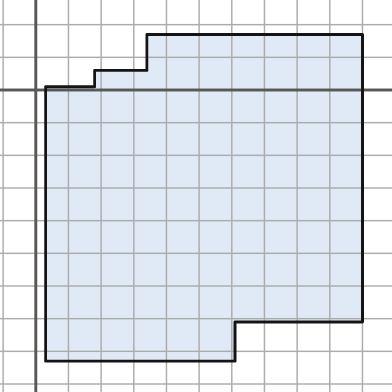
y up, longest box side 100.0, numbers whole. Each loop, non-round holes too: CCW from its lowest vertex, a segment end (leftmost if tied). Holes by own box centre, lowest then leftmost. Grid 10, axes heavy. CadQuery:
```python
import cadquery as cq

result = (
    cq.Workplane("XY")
    .moveTo(3.0, -83.0)
    .lineTo(61.0, -83.0)
    .lineTo(61.0, -71.0)
    .lineTo(100.0, -71.0)
    .lineTo(100.0, 17.0)
    .lineTo(34.0, 17.0)
    .lineTo(34.0, 6.0)
    .lineTo(18.0, 6.0)
    .lineTo(18.0, 1.0)
    .lineTo(3.0, 1.0)
    .close()
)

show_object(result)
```